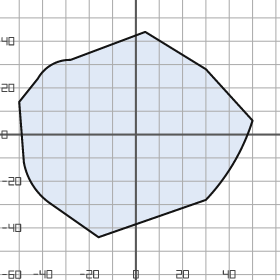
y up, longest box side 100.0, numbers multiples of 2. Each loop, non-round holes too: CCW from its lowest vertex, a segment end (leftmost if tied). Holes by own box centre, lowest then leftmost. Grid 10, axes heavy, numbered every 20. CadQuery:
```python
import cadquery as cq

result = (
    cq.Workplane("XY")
    .moveTo(-16.0, -44.0)
    .lineTo(30.0, -28.0)
    .threePointArc((42.0, -12.0), (50.0, 6.0))
    .lineTo(30.0, 28.0)
    .lineTo(4.0, 44.0)
    .lineTo(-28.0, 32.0)
    .threePointArc((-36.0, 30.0), (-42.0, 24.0))
    .lineTo(-50.0, 14.0)
    .lineTo(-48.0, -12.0)
    .threePointArc((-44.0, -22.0), (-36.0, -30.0))
    .close()
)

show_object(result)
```